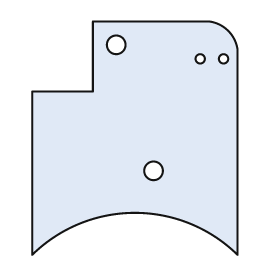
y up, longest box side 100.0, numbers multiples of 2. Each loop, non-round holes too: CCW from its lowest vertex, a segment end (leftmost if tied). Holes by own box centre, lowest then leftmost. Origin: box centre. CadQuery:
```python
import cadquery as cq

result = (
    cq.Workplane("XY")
    .moveTo(-44.0, -50.0)
    .threePointArc((0.0, -32.0), (44.0, -50.0))
    .lineTo(44.0, 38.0)
    .threePointArc((40.0, 46.0), (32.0, 50.0))
    .lineTo(-18.0, 50.0)
    .lineTo(-18.0, 20.0)
    .lineTo(-44.0, 20.0)
    .close()
    .moveTo(8.0, -14.0)
    .circle(4.0)
    .moveTo(28.0, 34.0)
    .circle(2.0)
    .moveTo(38.0, 34.0)
    .circle(2.0)
    .moveTo(-8.0, 40.0)
    .circle(4.0)
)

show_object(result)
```